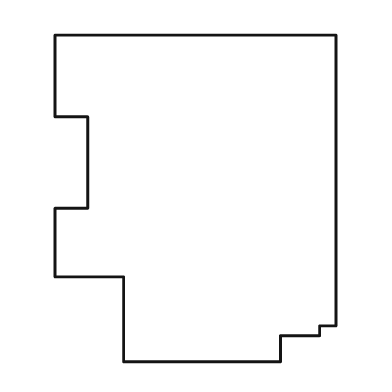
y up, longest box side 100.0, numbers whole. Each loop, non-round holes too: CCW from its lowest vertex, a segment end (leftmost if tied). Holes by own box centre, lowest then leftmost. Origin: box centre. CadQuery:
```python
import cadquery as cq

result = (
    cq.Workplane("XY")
    .moveTo(-22.0, -50.0)
    .lineTo(26.0, -50.0)
    .lineTo(26.0, -42.0)
    .lineTo(38.0, -42.0)
    .lineTo(38.0, -39.0)
    .lineTo(43.0, -39.0)
    .lineTo(43.0, 50.0)
    .lineTo(-43.0, 50.0)
    .lineTo(-43.0, 25.0)
    .lineTo(-33.0, 25.0)
    .lineTo(-33.0, -3.0)
    .lineTo(-43.0, -3.0)
    .lineTo(-43.0, -24.0)
    .lineTo(-22.0, -24.0)
    .close()
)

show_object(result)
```